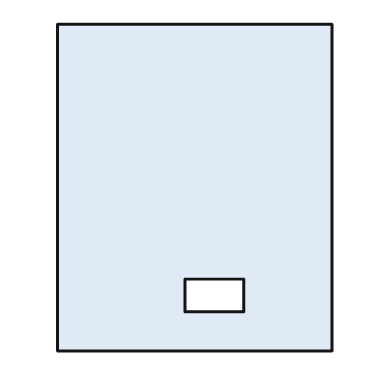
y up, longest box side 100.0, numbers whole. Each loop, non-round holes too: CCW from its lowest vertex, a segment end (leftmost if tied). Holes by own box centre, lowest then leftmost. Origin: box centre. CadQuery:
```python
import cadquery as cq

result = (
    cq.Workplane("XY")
    .moveTo(-42.0, -50.0)
    .lineTo(42.0, -50.0)
    .lineTo(42.0, 50.0)
    .lineTo(-42.0, 50.0)
    .close()
    .moveTo(-3.0, -38.0)
    .lineTo(15.0, -38.0)
    .lineTo(15.0, -28.0)
    .lineTo(-3.0, -28.0)
    .close()
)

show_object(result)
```